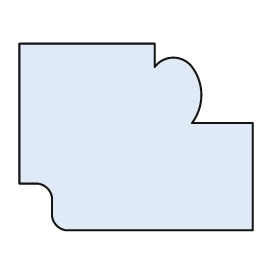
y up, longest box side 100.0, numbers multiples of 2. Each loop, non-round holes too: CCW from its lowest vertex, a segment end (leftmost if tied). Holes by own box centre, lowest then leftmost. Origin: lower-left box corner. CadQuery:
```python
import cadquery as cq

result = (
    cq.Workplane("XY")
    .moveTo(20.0, 0.0)
    .lineTo(100.0, 0.0)
    .lineTo(100.0, 46.0)
    .lineTo(74.0, 46.0)
    .threePointArc((78.0, 58.0), (74.0, 70.0))
    .threePointArc((66.0, 74.0), (58.0, 70.0))
    .lineTo(58.0, 80.0)
    .lineTo(0.0, 80.0)
    .lineTo(0.0, 20.0)
    .lineTo(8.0, 20.0)
    .threePointArc((12.0, 18.0), (14.0, 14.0))
    .lineTo(14.0, 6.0)
    .threePointArc((16.0, 2.0), (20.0, 0.0))
    .close()
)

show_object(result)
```